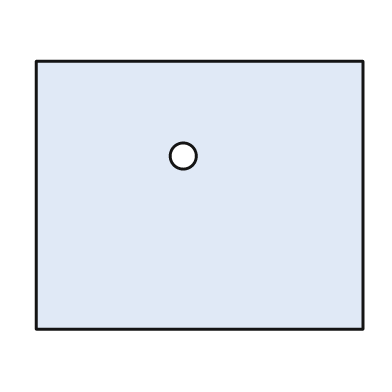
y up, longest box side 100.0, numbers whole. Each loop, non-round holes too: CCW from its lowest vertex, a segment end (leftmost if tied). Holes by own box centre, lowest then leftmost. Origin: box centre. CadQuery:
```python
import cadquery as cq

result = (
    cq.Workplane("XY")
    .moveTo(-50.0, -41.0)
    .lineTo(50.0, -41.0)
    .lineTo(50.0, 41.0)
    .lineTo(-50.0, 41.0)
    .close()
    .moveTo(-5.0, 12.0)
    .circle(4.0)
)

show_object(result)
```